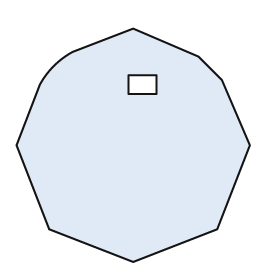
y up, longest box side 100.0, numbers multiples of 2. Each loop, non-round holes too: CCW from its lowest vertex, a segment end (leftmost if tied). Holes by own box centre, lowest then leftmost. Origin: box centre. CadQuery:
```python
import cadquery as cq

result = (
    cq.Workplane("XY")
    .moveTo(0.0, -50.0)
    .lineTo(36.0, -36.0)
    .lineTo(50.0, 0.0)
    .lineTo(38.0, 28.0)
    .lineTo(28.0, 38.0)
    .lineTo(0.0, 50.0)
    .lineTo(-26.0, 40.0)
    .threePointArc((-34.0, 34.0), (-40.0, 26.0))
    .lineTo(-50.0, 0.0)
    .lineTo(-36.0, -36.0)
    .close()
    .moveTo(-2.0, 22.0)
    .lineTo(10.0, 22.0)
    .lineTo(10.0, 30.0)
    .lineTo(-2.0, 30.0)
    .close()
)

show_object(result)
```